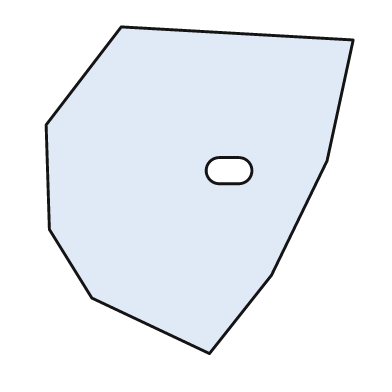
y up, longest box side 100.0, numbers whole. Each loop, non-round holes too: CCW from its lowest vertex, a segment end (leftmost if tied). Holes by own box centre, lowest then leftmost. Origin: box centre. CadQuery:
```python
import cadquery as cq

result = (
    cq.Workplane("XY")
    .moveTo(3.0, -50.0)
    .lineTo(22.0, -26.0)
    .lineTo(39.0, 9.0)
    .lineTo(47.0, 46.0)
    .lineTo(-24.0, 50.0)
    .lineTo(-47.0, 20.0)
    .lineTo(-46.0, -12.0)
    .lineTo(-33.0, -33.0)
    .close()
    .moveTo(6.0, 2.0)
    .lineTo(12.0, 2.0)
    .threePointArc((16.0, 6.0), (12.0, 10.0))
    .lineTo(6.0, 10.0)
    .threePointArc((2.0, 6.0), (6.0, 2.0))
    .close()
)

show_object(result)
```